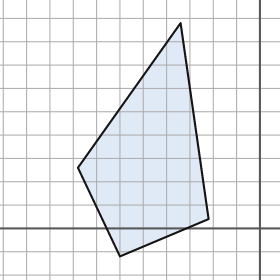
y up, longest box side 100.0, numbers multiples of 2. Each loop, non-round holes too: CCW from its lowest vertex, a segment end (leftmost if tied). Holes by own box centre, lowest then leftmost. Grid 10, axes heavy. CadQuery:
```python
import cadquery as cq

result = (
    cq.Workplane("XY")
    .moveTo(-60.0, -12.0)
    .lineTo(-22.0, 4.0)
    .lineTo(-34.0, 88.0)
    .lineTo(-78.0, 26.0)
    .close()
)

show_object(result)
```